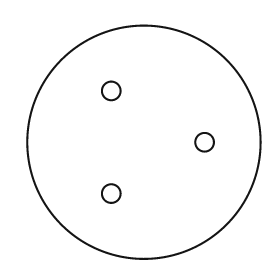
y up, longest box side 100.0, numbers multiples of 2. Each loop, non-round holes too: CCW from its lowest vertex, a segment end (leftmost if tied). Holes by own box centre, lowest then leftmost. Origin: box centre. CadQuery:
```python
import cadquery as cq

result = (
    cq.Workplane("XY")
    .moveTo(0.0, 0.0)
    .circle(50.0)
    .moveTo(-14.0, -22.0)
    .circle(4.0)
    .moveTo(26.0, 0.0)
    .circle(4.0)
    .moveTo(-14.0, 22.0)
    .circle(4.0)
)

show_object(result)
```